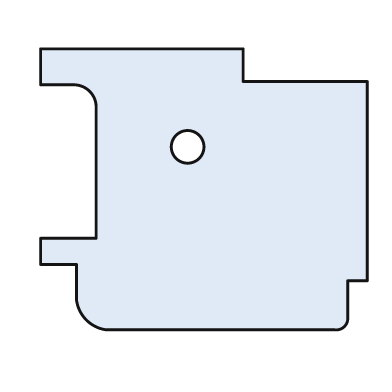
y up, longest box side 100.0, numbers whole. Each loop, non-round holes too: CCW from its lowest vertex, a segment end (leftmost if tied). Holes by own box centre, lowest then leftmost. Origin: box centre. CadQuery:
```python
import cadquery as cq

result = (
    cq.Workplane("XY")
    .moveTo(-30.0, -43.0)
    .lineTo(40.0, -43.0)
    .threePointArc((43.0, -42.0), (44.0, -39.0))
    .lineTo(44.0, -28.0)
    .lineTo(50.0, -28.0)
    .lineTo(50.0, 33.0)
    .lineTo(12.0, 33.0)
    .lineTo(12.0, 43.0)
    .lineTo(-50.0, 43.0)
    .lineTo(-50.0, 32.0)
    .lineTo(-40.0, 32.0)
    .threePointArc((-35.0, 30.0), (-33.0, 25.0))
    .lineTo(-33.0, -15.0)
    .lineTo(-50.0, -15.0)
    .lineTo(-50.0, -23.0)
    .lineTo(-39.0, -23.0)
    .lineTo(-39.0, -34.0)
    .threePointArc((-36.0, -40.0), (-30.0, -43.0))
    .close()
    .moveTo(-5.0, 13.0)
    .circle(5.0)
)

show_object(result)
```